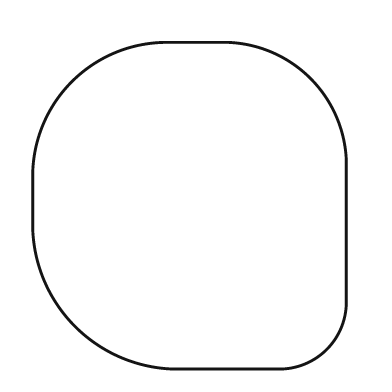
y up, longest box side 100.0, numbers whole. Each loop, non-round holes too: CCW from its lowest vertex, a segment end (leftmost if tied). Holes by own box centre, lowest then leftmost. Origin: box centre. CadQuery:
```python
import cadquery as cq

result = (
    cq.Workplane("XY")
    .moveTo(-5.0, -50.0)
    .lineTo(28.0, -50.0)
    .threePointArc((42.0, -44.0), (48.0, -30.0))
    .lineTo(48.0, 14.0)
    .threePointArc((37.0, 39.0), (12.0, 50.0))
    .lineTo(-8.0, 50.0)
    .threePointArc((-36.0, 38.0), (-48.0, 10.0))
    .lineTo(-48.0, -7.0)
    .threePointArc((-35.0, -37.0), (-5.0, -50.0))
    .close()
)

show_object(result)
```